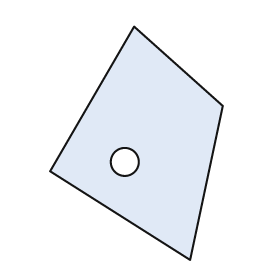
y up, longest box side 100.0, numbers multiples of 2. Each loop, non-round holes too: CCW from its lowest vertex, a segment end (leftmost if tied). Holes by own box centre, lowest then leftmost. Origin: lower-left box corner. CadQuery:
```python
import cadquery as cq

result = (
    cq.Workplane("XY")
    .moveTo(60.0, 0.0)
    .lineTo(74.0, 66.0)
    .lineTo(36.0, 100.0)
    .lineTo(0.0, 38.0)
    .close()
    .moveTo(32.0, 42.0)
    .circle(6.0)
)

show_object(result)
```